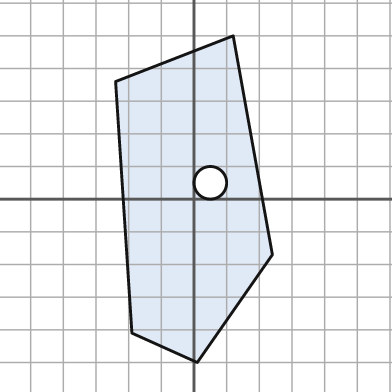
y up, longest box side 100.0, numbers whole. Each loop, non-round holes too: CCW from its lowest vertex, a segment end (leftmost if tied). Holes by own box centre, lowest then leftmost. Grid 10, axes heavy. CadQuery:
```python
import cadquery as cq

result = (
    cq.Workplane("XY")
    .moveTo(1.0, -50.0)
    .lineTo(24.0, -17.0)
    .lineTo(12.0, 50.0)
    .lineTo(-24.0, 36.0)
    .lineTo(-19.0, -41.0)
    .close()
    .moveTo(5.0, 5.0)
    .circle(5.0)
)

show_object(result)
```